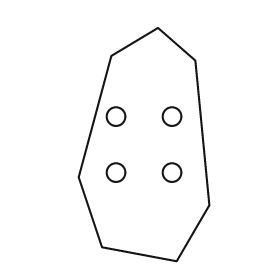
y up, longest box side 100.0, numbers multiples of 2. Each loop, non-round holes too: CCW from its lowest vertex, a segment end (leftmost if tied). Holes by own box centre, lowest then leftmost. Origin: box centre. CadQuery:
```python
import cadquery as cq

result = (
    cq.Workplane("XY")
    .moveTo(14.0, -50.0)
    .lineTo(28.0, -26.0)
    .lineTo(22.0, 36.0)
    .lineTo(6.0, 50.0)
    .lineTo(-14.0, 38.0)
    .lineTo(-28.0, -14.0)
    .lineTo(-18.0, -44.0)
    .close()
    .moveTo(-12.0, -12.0)
    .circle(4.0)
    .moveTo(12.0, -12.0)
    .circle(4.0)
    .moveTo(-12.0, 12.0)
    .circle(4.0)
    .moveTo(12.0, 12.0)
    .circle(4.0)
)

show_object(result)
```